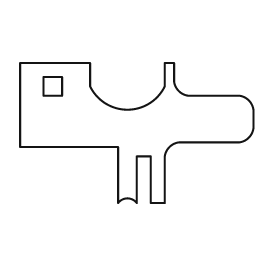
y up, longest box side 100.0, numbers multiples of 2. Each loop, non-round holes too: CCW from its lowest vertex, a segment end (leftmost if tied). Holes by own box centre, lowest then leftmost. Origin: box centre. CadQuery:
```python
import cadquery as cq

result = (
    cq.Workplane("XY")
    .moveTo(-8.0, -30.0)
    .threePointArc((-4.0, -28.0), (0.0, -30.0))
    .lineTo(0.0, -10.0)
    .lineTo(6.0, -10.0)
    .lineTo(6.0, -30.0)
    .lineTo(12.0, -30.0)
    .lineTo(12.0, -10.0)
    .threePointArc((14.0, -6.0), (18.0, -4.0))
    .lineTo(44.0, -4.0)
    .threePointArc((48.0, -2.0), (50.0, 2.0))
    .lineTo(50.0, 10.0)
    .threePointArc((48.0, 14.0), (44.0, 16.0))
    .lineTo(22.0, 16.0)
    .threePointArc((18.0, 18.0), (16.0, 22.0))
    .lineTo(16.0, 30.0)
    .lineTo(12.0, 30.0)
    .lineTo(12.0, 20.0)
    .threePointArc((-4.0, 10.0), (-20.0, 20.0))
    .lineTo(-20.0, 30.0)
    .lineTo(-50.0, 30.0)
    .lineTo(-50.0, -6.0)
    .lineTo(-8.0, -6.0)
    .close()
    .moveTo(-40.0, 16.0)
    .lineTo(-32.0, 16.0)
    .lineTo(-32.0, 24.0)
    .lineTo(-40.0, 24.0)
    .close()
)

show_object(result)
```